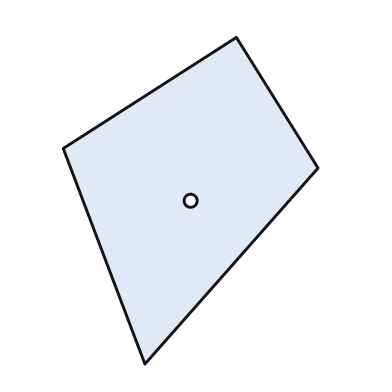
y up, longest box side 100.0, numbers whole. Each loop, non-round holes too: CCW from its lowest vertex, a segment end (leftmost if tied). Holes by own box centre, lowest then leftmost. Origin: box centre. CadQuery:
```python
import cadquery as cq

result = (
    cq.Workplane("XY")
    .moveTo(-14.0, -50.0)
    .lineTo(39.0, 10.0)
    .lineTo(14.0, 50.0)
    .lineTo(-39.0, 16.0)
    .close()
    .moveTo(0.0, 0.0)
    .circle(2.0)
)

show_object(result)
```